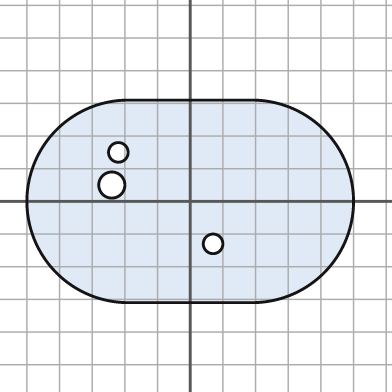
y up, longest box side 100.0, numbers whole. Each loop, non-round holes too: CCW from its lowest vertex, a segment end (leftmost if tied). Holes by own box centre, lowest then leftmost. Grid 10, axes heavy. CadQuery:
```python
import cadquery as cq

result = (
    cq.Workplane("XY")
    .moveTo(-19.0, -31.0)
    .lineTo(19.0, -31.0)
    .threePointArc((50.0, 0.0), (19.0, 31.0))
    .lineTo(-19.0, 31.0)
    .threePointArc((-50.0, 0.0), (-19.0, -31.0))
    .close()
    .moveTo(7.0, -13.0)
    .circle(3.0)
    .moveTo(-24.0, 5.0)
    .circle(4.0)
    .moveTo(-22.0, 15.0)
    .circle(3.0)
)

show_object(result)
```